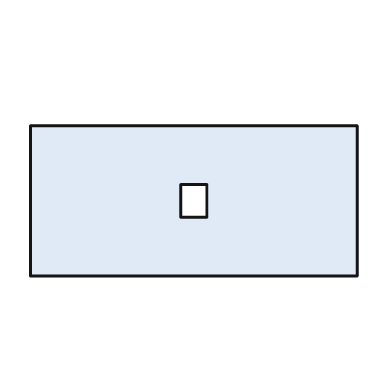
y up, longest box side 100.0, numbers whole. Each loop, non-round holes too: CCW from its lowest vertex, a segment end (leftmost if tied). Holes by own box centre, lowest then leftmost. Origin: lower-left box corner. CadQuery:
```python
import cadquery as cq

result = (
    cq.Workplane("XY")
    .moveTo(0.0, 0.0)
    .lineTo(100.0, 0.0)
    .lineTo(100.0, 46.0)
    .lineTo(0.0, 46.0)
    .close()
    .moveTo(46.0, 18.0)
    .lineTo(54.0, 18.0)
    .lineTo(54.0, 28.0)
    .lineTo(46.0, 28.0)
    .close()
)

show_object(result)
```